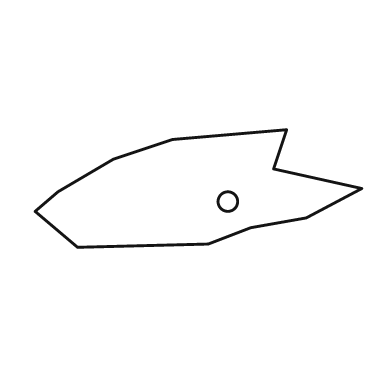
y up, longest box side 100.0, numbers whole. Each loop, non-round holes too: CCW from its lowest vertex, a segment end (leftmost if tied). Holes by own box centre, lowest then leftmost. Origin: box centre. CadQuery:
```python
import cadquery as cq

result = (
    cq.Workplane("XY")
    .moveTo(-37.0, -18.0)
    .lineTo(3.0, -17.0)
    .lineTo(16.0, -12.0)
    .lineTo(33.0, -9.0)
    .lineTo(50.0, 0.0)
    .lineTo(23.0, 6.0)
    .lineTo(27.0, 18.0)
    .lineTo(-8.0, 15.0)
    .lineTo(-26.0, 9.0)
    .lineTo(-43.0, -1.0)
    .lineTo(-50.0, -7.0)
    .close()
    .moveTo(9.0, -4.0)
    .circle(3.0)
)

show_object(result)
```